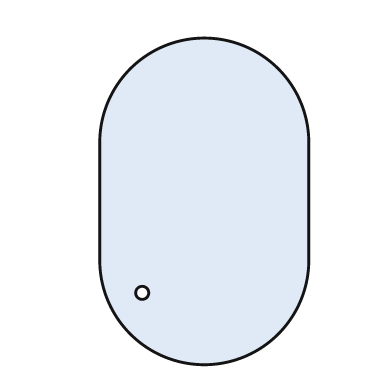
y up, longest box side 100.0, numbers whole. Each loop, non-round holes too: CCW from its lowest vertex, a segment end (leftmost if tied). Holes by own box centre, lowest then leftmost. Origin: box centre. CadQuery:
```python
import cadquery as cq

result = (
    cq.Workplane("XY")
    .moveTo(-32.0, -18.0)
    .threePointArc((0.0, -50.0), (32.0, -18.0))
    .lineTo(32.0, 18.0)
    .threePointArc((0.0, 50.0), (-32.0, 18.0))
    .close()
    .moveTo(-19.0, -28.0)
    .circle(2.0)
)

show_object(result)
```